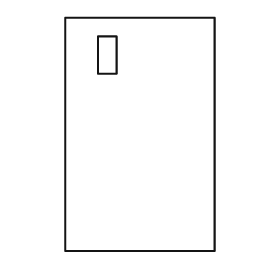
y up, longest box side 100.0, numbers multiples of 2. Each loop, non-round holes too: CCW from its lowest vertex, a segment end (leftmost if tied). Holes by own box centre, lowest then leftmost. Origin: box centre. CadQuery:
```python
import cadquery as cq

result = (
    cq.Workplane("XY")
    .moveTo(-32.0, -50.0)
    .lineTo(32.0, -50.0)
    .lineTo(32.0, 50.0)
    .lineTo(-32.0, 50.0)
    .close()
    .moveTo(-18.0, 26.0)
    .lineTo(-10.0, 26.0)
    .lineTo(-10.0, 42.0)
    .lineTo(-18.0, 42.0)
    .close()
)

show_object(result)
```